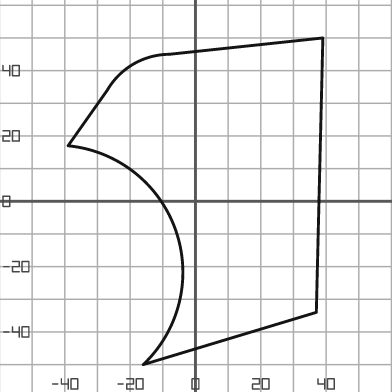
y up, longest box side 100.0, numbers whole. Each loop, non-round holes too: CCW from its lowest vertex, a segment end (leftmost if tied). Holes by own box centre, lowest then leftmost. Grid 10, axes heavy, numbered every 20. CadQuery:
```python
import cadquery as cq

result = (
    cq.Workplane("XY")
    .moveTo(-16.0, -50.0)
    .lineTo(37.0, -34.0)
    .lineTo(39.0, 50.0)
    .lineTo(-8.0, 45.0)
    .threePointArc((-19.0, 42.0), (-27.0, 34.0))
    .lineTo(-39.0, 17.0)
    .threePointArc((-6.0, -9.0), (-16.0, -50.0))
    .close()
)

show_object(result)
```